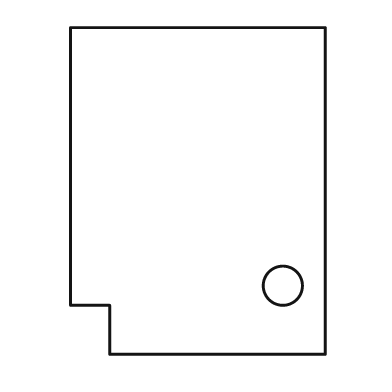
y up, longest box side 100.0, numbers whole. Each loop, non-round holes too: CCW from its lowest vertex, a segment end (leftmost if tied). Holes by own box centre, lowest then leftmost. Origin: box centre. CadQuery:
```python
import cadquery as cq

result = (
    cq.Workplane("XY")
    .moveTo(-27.0, -50.0)
    .lineTo(39.0, -50.0)
    .lineTo(39.0, 50.0)
    .lineTo(-39.0, 50.0)
    .lineTo(-39.0, -35.0)
    .lineTo(-27.0, -35.0)
    .close()
    .moveTo(26.0, -29.0)
    .circle(6.0)
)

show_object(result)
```